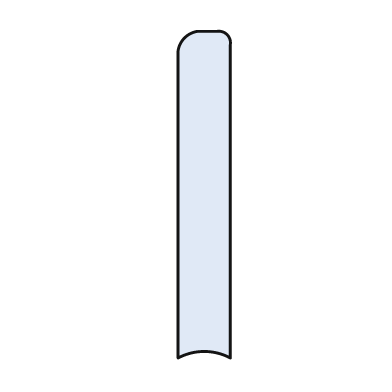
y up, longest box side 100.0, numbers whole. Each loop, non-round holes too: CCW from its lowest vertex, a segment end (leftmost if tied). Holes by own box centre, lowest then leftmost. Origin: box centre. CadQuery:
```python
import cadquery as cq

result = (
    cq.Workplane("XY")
    .moveTo(-8.0, -50.0)
    .threePointArc((0.0, -48.0), (8.0, -50.0))
    .lineTo(8.0, 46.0)
    .threePointArc((7.0, 49.0), (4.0, 50.0))
    .lineTo(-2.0, 50.0)
    .threePointArc((-6.0, 48.0), (-8.0, 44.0))
    .close()
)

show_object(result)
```